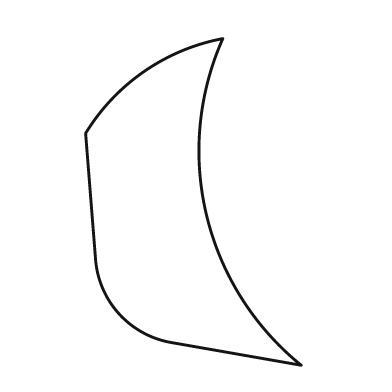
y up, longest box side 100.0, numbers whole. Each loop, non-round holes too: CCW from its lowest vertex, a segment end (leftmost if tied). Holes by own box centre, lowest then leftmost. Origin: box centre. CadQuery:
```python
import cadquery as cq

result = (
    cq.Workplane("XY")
    .moveTo(33.0, -50.0)
    .threePointArc((4.0, -4.0), (9.0, 50.0))
    .threePointArc((-15.0, 40.0), (-33.0, 21.0))
    .lineTo(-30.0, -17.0)
    .threePointArc((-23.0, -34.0), (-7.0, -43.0))
    .close()
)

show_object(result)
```